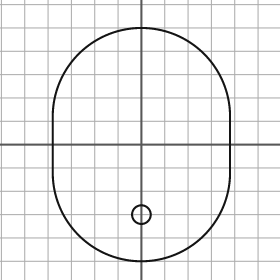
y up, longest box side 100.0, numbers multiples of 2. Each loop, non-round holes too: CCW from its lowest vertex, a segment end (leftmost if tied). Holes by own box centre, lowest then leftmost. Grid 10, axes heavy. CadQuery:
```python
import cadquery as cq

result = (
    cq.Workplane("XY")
    .moveTo(-38.0, -12.0)
    .threePointArc((0.0, -50.0), (38.0, -12.0))
    .lineTo(38.0, 12.0)
    .threePointArc((0.0, 50.0), (-38.0, 12.0))
    .close()
    .moveTo(0.0, -30.0)
    .circle(4.0)
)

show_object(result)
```